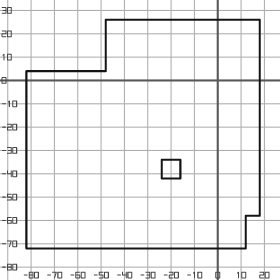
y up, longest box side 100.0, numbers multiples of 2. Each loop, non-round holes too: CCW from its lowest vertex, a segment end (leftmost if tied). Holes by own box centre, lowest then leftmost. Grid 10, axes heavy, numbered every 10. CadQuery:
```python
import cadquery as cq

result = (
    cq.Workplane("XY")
    .moveTo(-82.0, -72.0)
    .lineTo(12.0, -72.0)
    .lineTo(12.0, -58.0)
    .lineTo(18.0, -58.0)
    .lineTo(18.0, 26.0)
    .lineTo(-48.0, 26.0)
    .lineTo(-48.0, 4.0)
    .lineTo(-82.0, 4.0)
    .close()
    .moveTo(-24.0, -42.0)
    .lineTo(-16.0, -42.0)
    .lineTo(-16.0, -34.0)
    .lineTo(-24.0, -34.0)
    .close()
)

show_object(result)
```